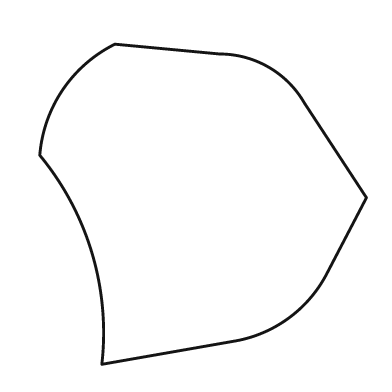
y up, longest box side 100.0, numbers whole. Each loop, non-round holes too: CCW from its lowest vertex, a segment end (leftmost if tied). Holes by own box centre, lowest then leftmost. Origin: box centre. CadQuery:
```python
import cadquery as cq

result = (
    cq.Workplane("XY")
    .moveTo(-31.0, -49.0)
    .lineTo(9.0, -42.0)
    .threePointArc((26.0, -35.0), (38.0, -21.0))
    .lineTo(50.0, 2.0)
    .lineTo(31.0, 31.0)
    .threePointArc((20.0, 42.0), (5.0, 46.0))
    .lineTo(-27.0, 49.0)
    .threePointArc((-43.0, 35.0), (-50.0, 15.0))
    .threePointArc((-34.0, -15.0), (-31.0, -49.0))
    .close()
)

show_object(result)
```